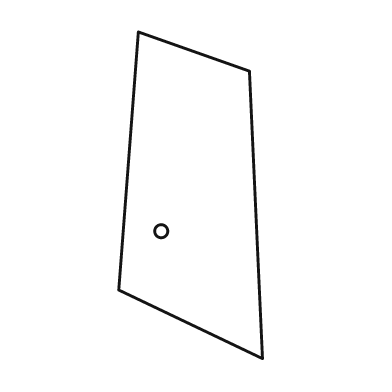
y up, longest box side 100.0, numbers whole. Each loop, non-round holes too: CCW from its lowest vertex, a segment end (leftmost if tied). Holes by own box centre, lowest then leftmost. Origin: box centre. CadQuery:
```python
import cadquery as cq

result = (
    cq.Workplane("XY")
    .moveTo(22.0, -50.0)
    .lineTo(18.0, 38.0)
    .lineTo(-16.0, 50.0)
    .lineTo(-22.0, -29.0)
    .close()
    .moveTo(-9.0, -11.0)
    .circle(2.0)
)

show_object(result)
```